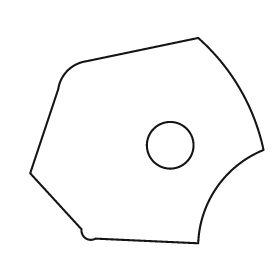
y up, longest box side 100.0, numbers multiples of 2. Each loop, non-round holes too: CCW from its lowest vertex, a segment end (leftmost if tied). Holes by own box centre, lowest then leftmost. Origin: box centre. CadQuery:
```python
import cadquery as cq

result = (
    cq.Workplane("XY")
    .moveTo(22.0, -44.0)
    .threePointArc((30.0, -20.0), (50.0, -4.0))
    .threePointArc((40.0, 22.0), (22.0, 44.0))
    .lineTo(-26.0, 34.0)
    .threePointArc((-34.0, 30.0), (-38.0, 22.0))
    .lineTo(-50.0, -14.0)
    .lineTo(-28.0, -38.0)
    .threePointArc((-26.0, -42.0), (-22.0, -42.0))
    .close()
    .moveTo(10.0, -2.0)
    .circle(10.0)
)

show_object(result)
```